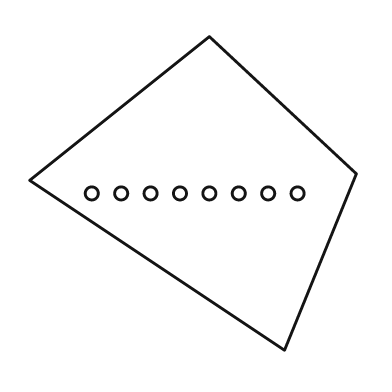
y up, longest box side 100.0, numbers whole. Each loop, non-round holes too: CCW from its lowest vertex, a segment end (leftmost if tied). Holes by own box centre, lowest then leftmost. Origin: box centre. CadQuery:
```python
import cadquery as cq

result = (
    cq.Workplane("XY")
    .moveTo(28.0, -48.0)
    .lineTo(50.0, 6.0)
    .lineTo(5.0, 48.0)
    .lineTo(-50.0, 4.0)
    .close()
    .moveTo(-31.0, 0.0)
    .circle(2.0)
    .moveTo(-22.0, 0.0)
    .circle(2.0)
    .moveTo(-13.0, 0.0)
    .circle(2.0)
    .moveTo(-4.0, 0.0)
    .circle(2.0)
    .moveTo(5.0, 0.0)
    .circle(2.0)
    .moveTo(14.0, 0.0)
    .circle(2.0)
    .moveTo(23.0, 0.0)
    .circle(2.0)
    .moveTo(32.0, 0.0)
    .circle(2.0)
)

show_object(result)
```